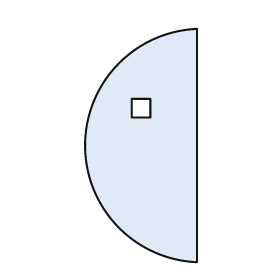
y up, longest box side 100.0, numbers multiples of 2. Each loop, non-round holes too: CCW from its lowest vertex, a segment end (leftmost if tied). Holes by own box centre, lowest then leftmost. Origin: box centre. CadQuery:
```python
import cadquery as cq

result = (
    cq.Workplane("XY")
    .moveTo(24.0, -50.0)
    .lineTo(24.0, 50.0)
    .threePointArc((-24.0, 0.0), (24.0, -50.0))
    .close()
    .moveTo(-4.0, 12.0)
    .lineTo(4.0, 12.0)
    .lineTo(4.0, 20.0)
    .lineTo(-4.0, 20.0)
    .close()
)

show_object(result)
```